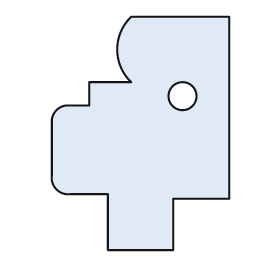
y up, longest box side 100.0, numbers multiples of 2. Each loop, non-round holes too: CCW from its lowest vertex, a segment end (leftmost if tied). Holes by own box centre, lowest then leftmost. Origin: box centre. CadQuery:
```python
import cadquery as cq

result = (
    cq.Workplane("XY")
    .moveTo(-14.0, -50.0)
    .lineTo(14.0, -50.0)
    .lineTo(14.0, -28.0)
    .lineTo(38.0, -28.0)
    .lineTo(38.0, 50.0)
    .lineTo(-4.0, 50.0)
    .threePointArc((-10.0, 36.0), (-4.0, 22.0))
    .lineTo(-22.0, 22.0)
    .lineTo(-22.0, 12.0)
    .lineTo(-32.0, 12.0)
    .threePointArc((-36.0, 10.0), (-38.0, 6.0))
    .lineTo(-38.0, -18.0)
    .threePointArc((-36.0, -24.0), (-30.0, -26.0))
    .lineTo(-14.0, -26.0)
    .close()
    .moveTo(18.0, 16.0)
    .circle(6.0)
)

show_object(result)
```